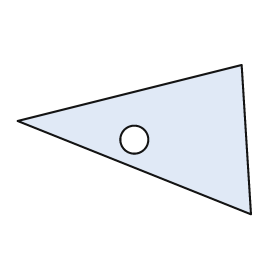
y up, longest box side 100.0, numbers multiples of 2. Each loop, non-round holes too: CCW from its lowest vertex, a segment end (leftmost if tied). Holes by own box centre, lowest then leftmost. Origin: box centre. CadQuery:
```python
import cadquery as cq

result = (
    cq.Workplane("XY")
    .moveTo(50.0, -32.0)
    .lineTo(46.0, 32.0)
    .lineTo(-50.0, 8.0)
    .close()
    .moveTo(0.0, 0.0)
    .circle(6.0)
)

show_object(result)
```